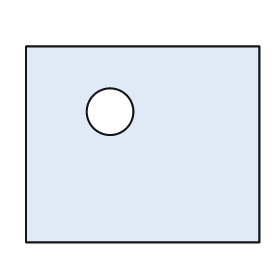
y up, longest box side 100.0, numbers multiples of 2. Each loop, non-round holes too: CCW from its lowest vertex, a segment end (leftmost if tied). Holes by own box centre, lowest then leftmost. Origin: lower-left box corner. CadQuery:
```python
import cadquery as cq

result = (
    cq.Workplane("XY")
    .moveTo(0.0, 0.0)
    .lineTo(100.0, 0.0)
    .lineTo(100.0, 84.0)
    .lineTo(0.0, 84.0)
    .close()
    .moveTo(36.0, 56.0)
    .circle(10.0)
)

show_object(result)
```